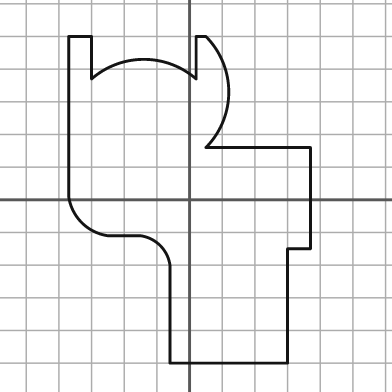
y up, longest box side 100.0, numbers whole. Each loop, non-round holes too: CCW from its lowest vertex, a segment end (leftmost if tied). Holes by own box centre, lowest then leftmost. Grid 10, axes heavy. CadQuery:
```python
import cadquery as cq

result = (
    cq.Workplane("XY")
    .moveTo(-6.0, -50.0)
    .lineTo(30.0, -50.0)
    .lineTo(30.0, -15.0)
    .lineTo(37.0, -15.0)
    .lineTo(37.0, 16.0)
    .lineTo(5.0, 16.0)
    .threePointArc((12.0, 33.0), (5.0, 50.0))
    .lineTo(2.0, 50.0)
    .lineTo(2.0, 37.0)
    .threePointArc((-14.0, 43.0), (-30.0, 37.0))
    .lineTo(-30.0, 50.0)
    .lineTo(-37.0, 50.0)
    .lineTo(-37.0, 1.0)
    .threePointArc((-33.0, -7.0), (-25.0, -11.0))
    .lineTo(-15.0, -11.0)
    .threePointArc((-9.0, -14.0), (-6.0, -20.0))
    .close()
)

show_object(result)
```